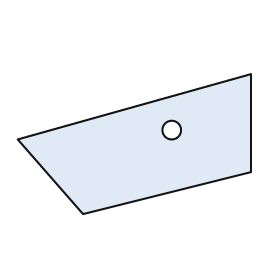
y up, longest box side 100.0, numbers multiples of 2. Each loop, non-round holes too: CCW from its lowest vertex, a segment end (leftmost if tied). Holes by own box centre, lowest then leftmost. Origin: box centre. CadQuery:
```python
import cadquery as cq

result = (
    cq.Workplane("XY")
    .moveTo(-22.0, -30.0)
    .lineTo(50.0, -12.0)
    .lineTo(50.0, 30.0)
    .lineTo(-50.0, 2.0)
    .close()
    .moveTo(16.0, 6.0)
    .circle(4.0)
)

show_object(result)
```